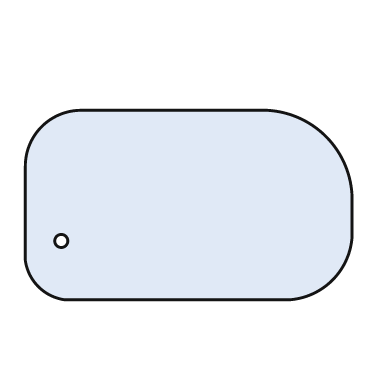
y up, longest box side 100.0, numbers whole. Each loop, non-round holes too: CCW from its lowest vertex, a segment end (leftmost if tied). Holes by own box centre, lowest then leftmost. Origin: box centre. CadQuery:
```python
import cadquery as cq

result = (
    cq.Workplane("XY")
    .moveTo(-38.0, -29.0)
    .lineTo(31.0, -29.0)
    .threePointArc((44.0, -23.0), (50.0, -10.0))
    .lineTo(50.0, 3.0)
    .threePointArc((42.0, 21.0), (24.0, 29.0))
    .lineTo(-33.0, 29.0)
    .threePointArc((-45.0, 24.0), (-50.0, 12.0))
    .lineTo(-50.0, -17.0)
    .threePointArc((-46.0, -25.0), (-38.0, -29.0))
    .close()
    .moveTo(-39.0, -11.0)
    .circle(2.0)
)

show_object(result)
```